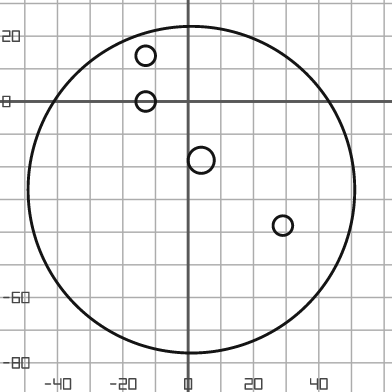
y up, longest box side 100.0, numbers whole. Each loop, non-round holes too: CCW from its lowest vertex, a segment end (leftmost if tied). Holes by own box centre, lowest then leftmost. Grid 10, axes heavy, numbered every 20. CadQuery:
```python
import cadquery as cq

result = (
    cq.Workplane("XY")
    .moveTo(1.0, -27.0)
    .circle(50.0)
    .moveTo(29.0, -38.0)
    .circle(3.0)
    .moveTo(4.0, -18.0)
    .circle(4.0)
    .moveTo(-13.0, 0.0)
    .circle(3.0)
    .moveTo(-13.0, 14.0)
    .circle(3.0)
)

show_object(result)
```